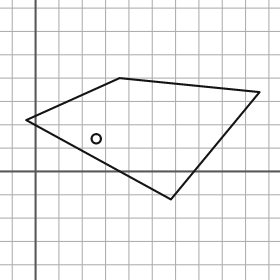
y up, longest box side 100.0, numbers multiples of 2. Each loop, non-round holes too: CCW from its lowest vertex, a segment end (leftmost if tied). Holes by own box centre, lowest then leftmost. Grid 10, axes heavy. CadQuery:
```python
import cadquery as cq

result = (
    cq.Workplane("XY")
    .moveTo(58.0, -12.0)
    .lineTo(96.0, 34.0)
    .lineTo(36.0, 40.0)
    .lineTo(-4.0, 22.0)
    .close()
    .moveTo(26.0, 14.0)
    .circle(2.0)
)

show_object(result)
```